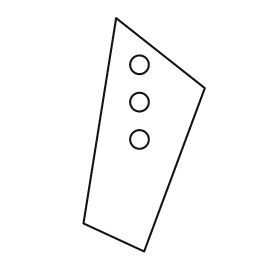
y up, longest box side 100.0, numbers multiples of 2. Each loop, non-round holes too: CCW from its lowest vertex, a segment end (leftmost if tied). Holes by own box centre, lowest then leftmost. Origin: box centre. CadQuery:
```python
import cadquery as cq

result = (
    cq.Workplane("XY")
    .moveTo(0.0, -50.0)
    .lineTo(26.0, 20.0)
    .lineTo(-12.0, 50.0)
    .lineTo(-26.0, -38.0)
    .close()
    .moveTo(-2.0, -2.0)
    .circle(4.0)
    .moveTo(-2.0, 14.0)
    .circle(4.0)
    .moveTo(-2.0, 30.0)
    .circle(4.0)
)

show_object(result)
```